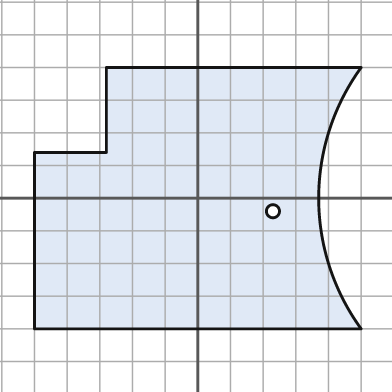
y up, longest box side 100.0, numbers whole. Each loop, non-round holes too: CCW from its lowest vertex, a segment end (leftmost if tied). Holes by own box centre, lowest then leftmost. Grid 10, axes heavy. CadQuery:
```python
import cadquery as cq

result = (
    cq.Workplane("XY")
    .moveTo(-50.0, -40.0)
    .lineTo(50.0, -40.0)
    .threePointArc((37.0, 0.0), (50.0, 40.0))
    .lineTo(-28.0, 40.0)
    .lineTo(-28.0, 14.0)
    .lineTo(-50.0, 14.0)
    .close()
    .moveTo(23.0, -4.0)
    .circle(2.0)
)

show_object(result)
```